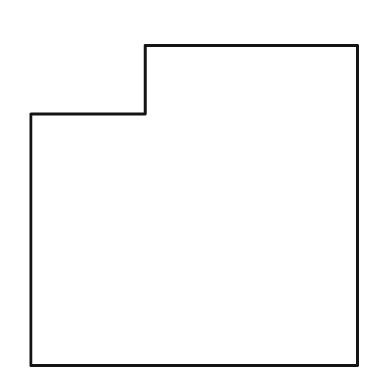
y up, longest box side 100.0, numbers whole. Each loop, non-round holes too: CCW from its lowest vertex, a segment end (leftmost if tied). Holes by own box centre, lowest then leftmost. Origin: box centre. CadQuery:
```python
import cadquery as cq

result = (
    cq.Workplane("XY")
    .moveTo(-50.0, -49.0)
    .lineTo(50.0, -49.0)
    .lineTo(50.0, 49.0)
    .lineTo(-15.0, 49.0)
    .lineTo(-15.0, 28.0)
    .lineTo(-50.0, 28.0)
    .close()
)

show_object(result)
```